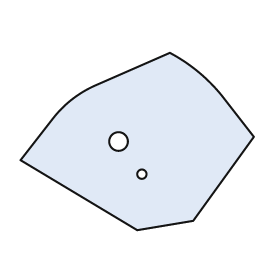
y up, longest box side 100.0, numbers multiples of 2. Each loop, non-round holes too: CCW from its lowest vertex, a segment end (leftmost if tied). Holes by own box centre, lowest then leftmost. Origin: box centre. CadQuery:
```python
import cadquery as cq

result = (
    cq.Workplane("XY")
    .moveTo(0.0, -38.0)
    .lineTo(24.0, -34.0)
    .lineTo(50.0, 2.0)
    .lineTo(36.0, 20.0)
    .threePointArc((26.0, 30.0), (14.0, 38.0))
    .lineTo(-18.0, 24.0)
    .threePointArc((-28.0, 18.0), (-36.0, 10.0))
    .lineTo(-50.0, -8.0)
    .close()
    .moveTo(2.0, -14.0)
    .circle(2.0)
    .moveTo(-8.0, 0.0)
    .circle(4.0)
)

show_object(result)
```